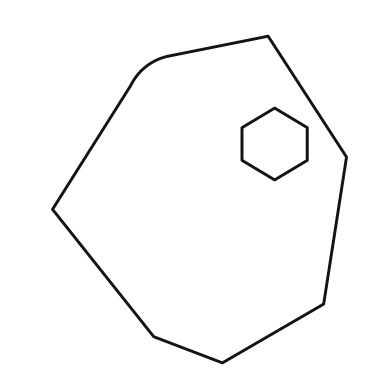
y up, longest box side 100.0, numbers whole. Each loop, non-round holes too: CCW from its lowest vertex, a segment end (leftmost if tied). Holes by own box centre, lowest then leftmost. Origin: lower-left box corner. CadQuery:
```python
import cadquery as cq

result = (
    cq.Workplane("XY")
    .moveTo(52.0, 0.0)
    .lineTo(83.0, 18.0)
    .lineTo(90.0, 63.0)
    .lineTo(66.0, 100.0)
    .lineTo(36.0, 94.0)
    .threePointArc((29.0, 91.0), (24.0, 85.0))
    .lineTo(0.0, 47.0)
    .lineTo(31.0, 8.0)
    .close()
    .moveTo(68.0, 56.0)
    .lineTo(78.0, 62.0)
    .lineTo(78.0, 72.0)
    .lineTo(68.0, 78.0)
    .lineTo(58.0, 72.0)
    .lineTo(58.0, 62.0)
    .close()
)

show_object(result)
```